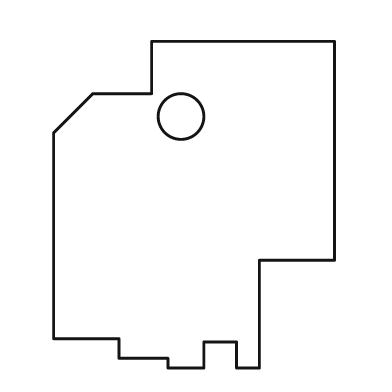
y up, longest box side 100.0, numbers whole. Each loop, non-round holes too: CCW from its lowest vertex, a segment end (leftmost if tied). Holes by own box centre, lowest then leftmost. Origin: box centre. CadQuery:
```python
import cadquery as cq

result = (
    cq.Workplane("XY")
    .moveTo(-8.0, -50.0)
    .lineTo(3.0, -50.0)
    .lineTo(3.0, -42.0)
    .lineTo(13.0, -42.0)
    .lineTo(13.0, -50.0)
    .lineTo(20.0, -50.0)
    .lineTo(20.0, -17.0)
    .lineTo(43.0, -17.0)
    .lineTo(43.0, 50.0)
    .lineTo(-13.0, 50.0)
    .lineTo(-13.0, 34.0)
    .lineTo(-31.0, 34.0)
    .lineTo(-43.0, 22.0)
    .lineTo(-43.0, -41.0)
    .lineTo(-23.0, -41.0)
    .lineTo(-23.0, -47.0)
    .lineTo(-8.0, -47.0)
    .close()
    .moveTo(-4.0, 27.0)
    .circle(7.0)
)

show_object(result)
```